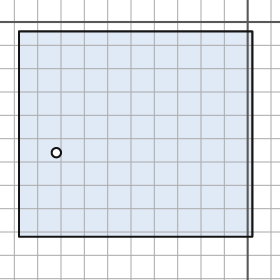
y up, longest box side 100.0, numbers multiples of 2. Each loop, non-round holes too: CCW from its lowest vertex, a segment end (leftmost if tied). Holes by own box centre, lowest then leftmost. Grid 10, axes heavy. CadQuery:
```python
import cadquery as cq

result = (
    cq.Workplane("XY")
    .moveTo(-98.0, -92.0)
    .lineTo(2.0, -92.0)
    .lineTo(2.0, -4.0)
    .lineTo(-98.0, -4.0)
    .close()
    .moveTo(-82.0, -56.0)
    .circle(2.0)
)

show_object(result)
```